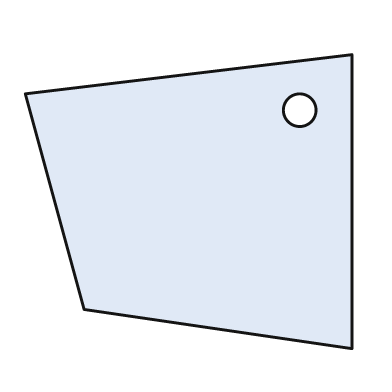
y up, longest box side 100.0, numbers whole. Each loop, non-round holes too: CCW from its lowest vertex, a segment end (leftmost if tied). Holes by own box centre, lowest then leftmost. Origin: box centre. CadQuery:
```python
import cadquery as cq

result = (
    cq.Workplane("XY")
    .moveTo(50.0, -45.0)
    .lineTo(50.0, 45.0)
    .lineTo(-50.0, 33.0)
    .lineTo(-32.0, -33.0)
    .close()
    .moveTo(34.0, 28.0)
    .circle(5.0)
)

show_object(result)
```